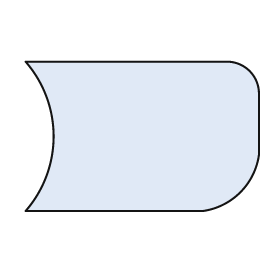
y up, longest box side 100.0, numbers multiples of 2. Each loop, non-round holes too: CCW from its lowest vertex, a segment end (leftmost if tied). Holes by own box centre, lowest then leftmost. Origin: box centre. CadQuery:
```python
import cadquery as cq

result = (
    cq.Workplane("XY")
    .moveTo(-50.0, -32.0)
    .lineTo(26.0, -32.0)
    .threePointArc((42.0, -24.0), (50.0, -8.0))
    .lineTo(50.0, 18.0)
    .threePointArc((46.0, 28.0), (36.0, 32.0))
    .lineTo(-50.0, 32.0)
    .threePointArc((-38.0, 0.0), (-50.0, -32.0))
    .close()
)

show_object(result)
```